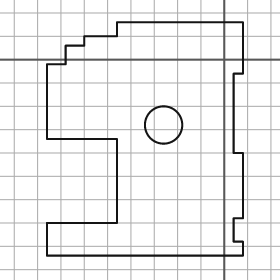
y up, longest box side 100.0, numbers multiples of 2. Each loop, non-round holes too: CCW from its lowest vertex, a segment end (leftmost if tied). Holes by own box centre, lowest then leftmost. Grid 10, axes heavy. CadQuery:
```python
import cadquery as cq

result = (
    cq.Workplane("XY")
    .moveTo(-76.0, -84.0)
    .lineTo(8.0, -84.0)
    .lineTo(8.0, -78.0)
    .lineTo(4.0, -78.0)
    .lineTo(4.0, -68.0)
    .lineTo(8.0, -68.0)
    .lineTo(8.0, -40.0)
    .lineTo(4.0, -40.0)
    .lineTo(4.0, -6.0)
    .lineTo(8.0, -6.0)
    .lineTo(8.0, 16.0)
    .lineTo(-46.0, 16.0)
    .lineTo(-46.0, 10.0)
    .lineTo(-60.0, 10.0)
    .lineTo(-60.0, 6.0)
    .lineTo(-68.0, 6.0)
    .lineTo(-68.0, -2.0)
    .lineTo(-76.0, -2.0)
    .lineTo(-76.0, -34.0)
    .lineTo(-46.0, -34.0)
    .lineTo(-46.0, -70.0)
    .lineTo(-76.0, -70.0)
    .close()
    .moveTo(-26.0, -28.0)
    .circle(8.0)
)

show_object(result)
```